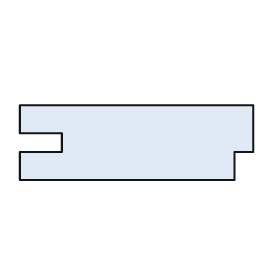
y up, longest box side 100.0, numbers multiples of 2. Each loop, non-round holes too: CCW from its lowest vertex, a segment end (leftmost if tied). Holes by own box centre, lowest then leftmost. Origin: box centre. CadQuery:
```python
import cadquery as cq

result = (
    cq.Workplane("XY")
    .moveTo(-50.0, -16.0)
    .lineTo(42.0, -16.0)
    .lineTo(42.0, -4.0)
    .lineTo(50.0, -4.0)
    .lineTo(50.0, 16.0)
    .lineTo(-50.0, 16.0)
    .lineTo(-50.0, 4.0)
    .lineTo(-32.0, 4.0)
    .lineTo(-32.0, -4.0)
    .lineTo(-50.0, -4.0)
    .close()
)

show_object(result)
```